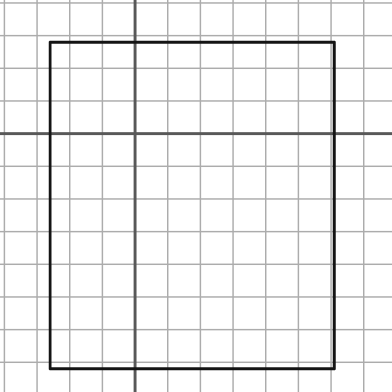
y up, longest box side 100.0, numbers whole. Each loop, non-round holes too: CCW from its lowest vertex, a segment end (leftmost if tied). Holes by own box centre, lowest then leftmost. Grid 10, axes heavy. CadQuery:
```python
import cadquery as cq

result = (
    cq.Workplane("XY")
    .moveTo(-26.0, -72.0)
    .lineTo(61.0, -72.0)
    .lineTo(61.0, 28.0)
    .lineTo(-26.0, 28.0)
    .close()
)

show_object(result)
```